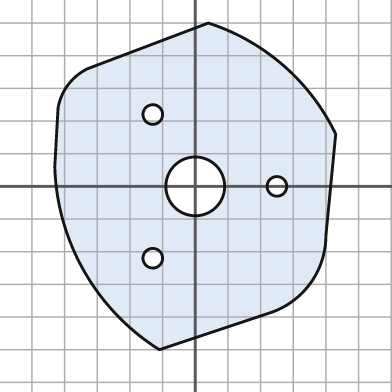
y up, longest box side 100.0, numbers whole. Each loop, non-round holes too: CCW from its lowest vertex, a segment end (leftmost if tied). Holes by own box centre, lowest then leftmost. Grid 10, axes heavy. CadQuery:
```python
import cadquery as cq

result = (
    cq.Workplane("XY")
    .moveTo(-11.0, -50.0)
    .lineTo(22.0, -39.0)
    .threePointArc((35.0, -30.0), (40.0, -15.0))
    .lineTo(43.0, 16.0)
    .threePointArc((27.0, 37.0), (4.0, 50.0))
    .lineTo(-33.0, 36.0)
    .threePointArc((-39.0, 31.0), (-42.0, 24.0))
    .lineTo(-43.0, 6.0)
    .threePointArc((-34.0, -26.0), (-11.0, -50.0))
    .close()
    .moveTo(-13.0, -22.0)
    .circle(3.0)
    .moveTo(0.0, 0.0)
    .circle(9.0)
    .moveTo(25.0, 0.0)
    .circle(3.0)
    .moveTo(-13.0, 22.0)
    .circle(3.0)
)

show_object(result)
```